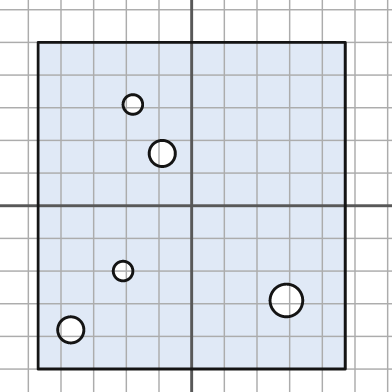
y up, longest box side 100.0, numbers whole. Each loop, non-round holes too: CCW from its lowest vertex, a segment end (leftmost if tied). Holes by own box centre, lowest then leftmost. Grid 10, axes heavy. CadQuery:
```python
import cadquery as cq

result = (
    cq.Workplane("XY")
    .moveTo(-47.0, -50.0)
    .lineTo(47.0, -50.0)
    .lineTo(47.0, 50.0)
    .lineTo(-47.0, 50.0)
    .close()
    .moveTo(-37.0, -38.0)
    .circle(4.0)
    .moveTo(29.0, -29.0)
    .circle(5.0)
    .moveTo(-21.0, -20.0)
    .circle(3.0)
    .moveTo(-9.0, 16.0)
    .circle(4.0)
    .moveTo(-18.0, 31.0)
    .circle(3.0)
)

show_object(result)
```